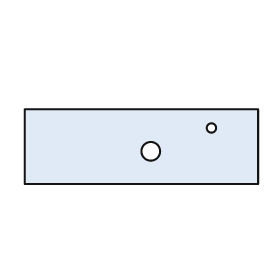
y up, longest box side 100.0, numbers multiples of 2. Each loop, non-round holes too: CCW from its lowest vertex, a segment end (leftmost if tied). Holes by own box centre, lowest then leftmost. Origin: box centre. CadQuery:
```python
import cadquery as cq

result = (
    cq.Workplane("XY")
    .moveTo(-50.0, -16.0)
    .lineTo(50.0, -16.0)
    .lineTo(50.0, 16.0)
    .lineTo(-50.0, 16.0)
    .close()
    .moveTo(4.0, -2.0)
    .circle(4.0)
    .moveTo(30.0, 8.0)
    .circle(2.0)
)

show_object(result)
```